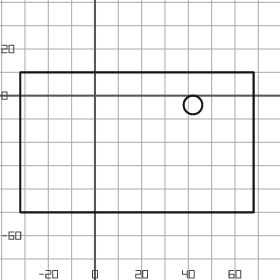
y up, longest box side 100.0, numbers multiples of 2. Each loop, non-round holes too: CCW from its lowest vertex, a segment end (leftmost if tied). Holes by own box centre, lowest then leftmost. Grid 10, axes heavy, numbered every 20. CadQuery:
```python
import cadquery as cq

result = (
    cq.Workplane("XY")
    .moveTo(-32.0, -50.0)
    .lineTo(68.0, -50.0)
    .lineTo(68.0, 10.0)
    .lineTo(-32.0, 10.0)
    .close()
    .moveTo(42.0, -4.0)
    .circle(4.0)
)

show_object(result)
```